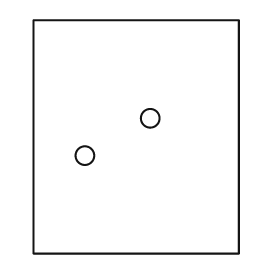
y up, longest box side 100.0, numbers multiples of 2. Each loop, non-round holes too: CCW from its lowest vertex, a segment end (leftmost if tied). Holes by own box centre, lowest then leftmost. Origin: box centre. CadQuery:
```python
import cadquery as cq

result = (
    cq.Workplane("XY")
    .moveTo(-44.0, -50.0)
    .lineTo(44.0, -50.0)
    .lineTo(44.0, 50.0)
    .lineTo(-44.0, 50.0)
    .close()
    .moveTo(-22.0, -8.0)
    .circle(4.0)
    .moveTo(6.0, 8.0)
    .circle(4.0)
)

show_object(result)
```